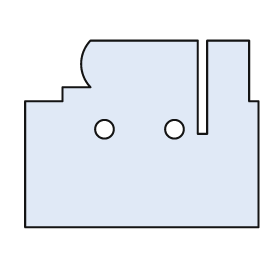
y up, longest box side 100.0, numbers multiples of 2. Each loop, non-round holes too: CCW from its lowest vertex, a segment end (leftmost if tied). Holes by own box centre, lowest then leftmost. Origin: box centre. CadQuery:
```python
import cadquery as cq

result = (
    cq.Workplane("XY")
    .moveTo(-50.0, -40.0)
    .lineTo(50.0, -40.0)
    .lineTo(50.0, 14.0)
    .lineTo(46.0, 14.0)
    .lineTo(46.0, 40.0)
    .lineTo(28.0, 40.0)
    .lineTo(28.0, 0.0)
    .lineTo(24.0, 0.0)
    .lineTo(24.0, 40.0)
    .lineTo(-22.0, 40.0)
    .threePointArc((-26.0, 30.0), (-22.0, 20.0))
    .lineTo(-34.0, 20.0)
    .lineTo(-34.0, 14.0)
    .lineTo(-50.0, 14.0)
    .close()
    .moveTo(-16.0, 2.0)
    .circle(4.0)
    .moveTo(14.0, 2.0)
    .circle(4.0)
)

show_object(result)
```